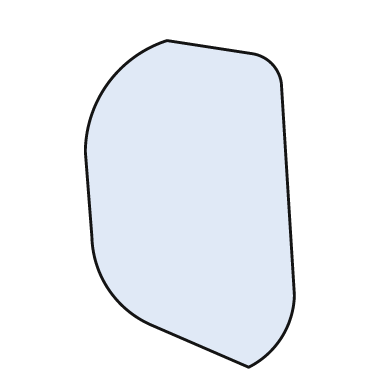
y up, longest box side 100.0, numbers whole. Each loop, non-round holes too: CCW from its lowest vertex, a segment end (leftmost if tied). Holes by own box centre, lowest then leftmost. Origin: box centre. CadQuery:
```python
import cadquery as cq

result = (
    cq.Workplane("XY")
    .moveTo(18.0, -50.0)
    .threePointArc((28.0, -41.0), (32.0, -28.0))
    .lineTo(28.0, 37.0)
    .threePointArc((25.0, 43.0), (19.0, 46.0))
    .lineTo(-7.0, 50.0)
    .threePointArc((-25.0, 37.0), (-32.0, 16.0))
    .lineTo(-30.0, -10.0)
    .threePointArc((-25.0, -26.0), (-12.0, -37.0))
    .close()
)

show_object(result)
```